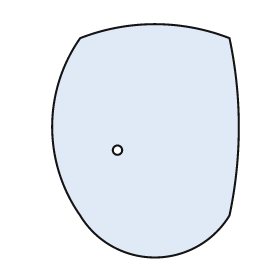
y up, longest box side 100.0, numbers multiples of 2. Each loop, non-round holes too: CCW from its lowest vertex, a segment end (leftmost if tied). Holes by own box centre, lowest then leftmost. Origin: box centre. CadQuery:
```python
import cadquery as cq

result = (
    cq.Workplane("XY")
    .moveTo(-28.0, -32.0)
    .threePointArc((4.0, -50.0), (36.0, -32.0))
    .threePointArc((40.0, 6.0), (36.0, 44.0))
    .threePointArc((4.0, 50.0), (-28.0, 44.0))
    .threePointArc((-40.0, 6.0), (-28.0, -32.0))
    .close()
    .moveTo(-12.0, -4.0)
    .circle(2.0)
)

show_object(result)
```